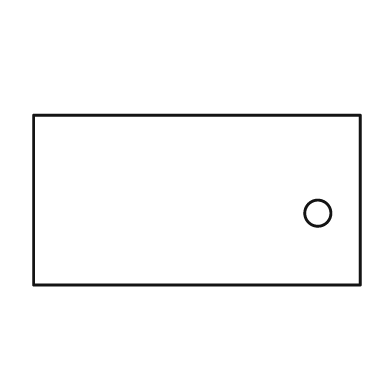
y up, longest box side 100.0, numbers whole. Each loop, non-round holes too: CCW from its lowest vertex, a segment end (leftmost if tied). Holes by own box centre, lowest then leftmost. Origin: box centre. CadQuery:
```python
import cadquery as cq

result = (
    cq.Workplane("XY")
    .moveTo(-50.0, -26.0)
    .lineTo(50.0, -26.0)
    .lineTo(50.0, 26.0)
    .lineTo(-50.0, 26.0)
    .close()
    .moveTo(37.0, -4.0)
    .circle(4.0)
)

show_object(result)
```